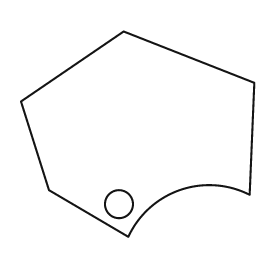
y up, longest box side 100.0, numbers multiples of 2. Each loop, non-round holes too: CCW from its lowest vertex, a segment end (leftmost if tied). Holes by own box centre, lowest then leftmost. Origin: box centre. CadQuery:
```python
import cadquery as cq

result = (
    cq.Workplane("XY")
    .moveTo(-4.0, -44.0)
    .threePointArc((18.0, -24.0), (48.0, -26.0))
    .lineTo(50.0, 22.0)
    .lineTo(-6.0, 44.0)
    .lineTo(-50.0, 14.0)
    .lineTo(-38.0, -24.0)
    .close()
    .moveTo(-8.0, -30.0)
    .circle(6.0)
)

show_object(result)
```